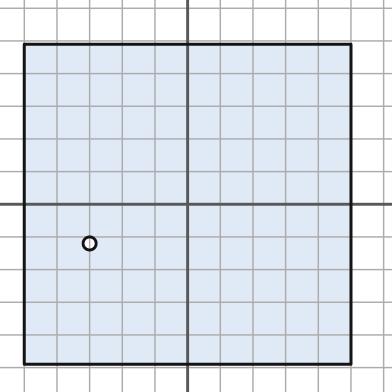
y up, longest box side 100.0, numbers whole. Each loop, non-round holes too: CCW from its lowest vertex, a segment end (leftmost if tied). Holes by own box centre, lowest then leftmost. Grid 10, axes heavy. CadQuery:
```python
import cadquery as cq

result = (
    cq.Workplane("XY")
    .moveTo(-50.0, -49.0)
    .lineTo(50.0, -49.0)
    .lineTo(50.0, 49.0)
    .lineTo(-50.0, 49.0)
    .close()
    .moveTo(-30.0, -12.0)
    .circle(2.0)
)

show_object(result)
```